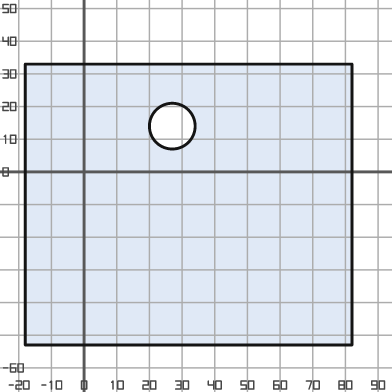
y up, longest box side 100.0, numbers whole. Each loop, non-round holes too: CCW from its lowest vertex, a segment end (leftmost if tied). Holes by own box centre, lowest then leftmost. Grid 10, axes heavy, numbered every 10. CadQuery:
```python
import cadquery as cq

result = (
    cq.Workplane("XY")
    .moveTo(-18.0, -53.0)
    .lineTo(82.0, -53.0)
    .lineTo(82.0, 33.0)
    .lineTo(-18.0, 33.0)
    .close()
    .moveTo(27.0, 14.0)
    .circle(7.0)
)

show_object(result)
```